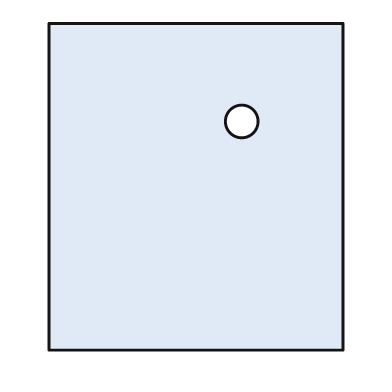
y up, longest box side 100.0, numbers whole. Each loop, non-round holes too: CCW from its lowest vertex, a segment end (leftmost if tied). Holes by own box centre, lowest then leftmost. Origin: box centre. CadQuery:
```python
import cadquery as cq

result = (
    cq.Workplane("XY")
    .moveTo(-45.0, -50.0)
    .lineTo(45.0, -50.0)
    .lineTo(45.0, 50.0)
    .lineTo(-45.0, 50.0)
    .close()
    .moveTo(14.0, 20.0)
    .circle(5.0)
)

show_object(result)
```